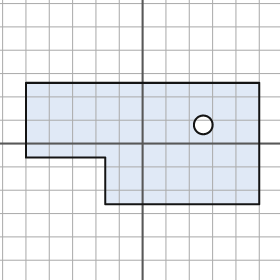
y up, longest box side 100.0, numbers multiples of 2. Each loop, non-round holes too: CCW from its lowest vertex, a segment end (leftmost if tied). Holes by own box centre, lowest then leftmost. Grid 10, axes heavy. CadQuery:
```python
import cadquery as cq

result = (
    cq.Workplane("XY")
    .moveTo(-16.0, -26.0)
    .lineTo(50.0, -26.0)
    .lineTo(50.0, 26.0)
    .lineTo(-50.0, 26.0)
    .lineTo(-50.0, -6.0)
    .lineTo(-16.0, -6.0)
    .close()
    .moveTo(26.0, 8.0)
    .circle(4.0)
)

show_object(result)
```